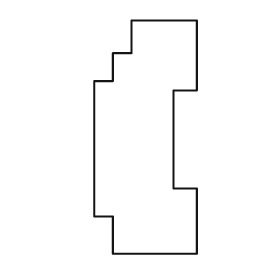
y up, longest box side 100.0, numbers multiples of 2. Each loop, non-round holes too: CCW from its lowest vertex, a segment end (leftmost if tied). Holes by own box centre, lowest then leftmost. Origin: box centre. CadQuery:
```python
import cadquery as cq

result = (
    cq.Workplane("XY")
    .moveTo(-14.0, -50.0)
    .lineTo(22.0, -50.0)
    .lineTo(22.0, -22.0)
    .lineTo(12.0, -22.0)
    .lineTo(12.0, 20.0)
    .lineTo(22.0, 20.0)
    .lineTo(22.0, 50.0)
    .lineTo(-6.0, 50.0)
    .lineTo(-6.0, 36.0)
    .lineTo(-14.0, 36.0)
    .lineTo(-14.0, 24.0)
    .lineTo(-22.0, 24.0)
    .lineTo(-22.0, -34.0)
    .lineTo(-14.0, -34.0)
    .close()
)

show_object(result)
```